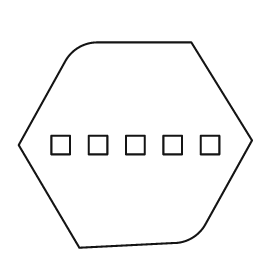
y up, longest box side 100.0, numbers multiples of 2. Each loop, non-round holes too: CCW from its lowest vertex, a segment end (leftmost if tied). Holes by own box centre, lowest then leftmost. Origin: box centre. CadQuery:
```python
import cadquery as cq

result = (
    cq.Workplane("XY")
    .moveTo(-24.0, -44.0)
    .lineTo(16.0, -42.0)
    .threePointArc((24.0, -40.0), (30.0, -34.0))
    .lineTo(50.0, 2.0)
    .lineTo(24.0, 44.0)
    .lineTo(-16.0, 44.0)
    .threePointArc((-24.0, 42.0), (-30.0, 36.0))
    .lineTo(-50.0, 0.0)
    .close()
    .moveTo(-36.0, -4.0)
    .lineTo(-28.0, -4.0)
    .lineTo(-28.0, 4.0)
    .lineTo(-36.0, 4.0)
    .close()
    .moveTo(-20.0, -4.0)
    .lineTo(-12.0, -4.0)
    .lineTo(-12.0, 4.0)
    .lineTo(-20.0, 4.0)
    .close()
    .moveTo(-4.0, -4.0)
    .lineTo(4.0, -4.0)
    .lineTo(4.0, 4.0)
    .lineTo(-4.0, 4.0)
    .close()
    .moveTo(12.0, -4.0)
    .lineTo(20.0, -4.0)
    .lineTo(20.0, 4.0)
    .lineTo(12.0, 4.0)
    .close()
    .moveTo(28.0, -4.0)
    .lineTo(36.0, -4.0)
    .lineTo(36.0, 4.0)
    .lineTo(28.0, 4.0)
    .close()
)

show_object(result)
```